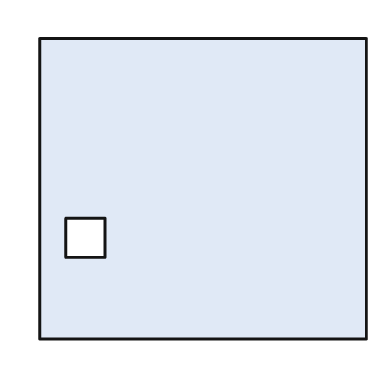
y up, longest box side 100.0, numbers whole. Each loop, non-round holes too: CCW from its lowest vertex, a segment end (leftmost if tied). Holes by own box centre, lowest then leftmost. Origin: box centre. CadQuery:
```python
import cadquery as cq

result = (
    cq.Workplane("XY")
    .moveTo(-50.0, -46.0)
    .lineTo(50.0, -46.0)
    .lineTo(50.0, 46.0)
    .lineTo(-50.0, 46.0)
    .close()
    .moveTo(-42.0, -21.0)
    .lineTo(-30.0, -21.0)
    .lineTo(-30.0, -9.0)
    .lineTo(-42.0, -9.0)
    .close()
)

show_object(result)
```